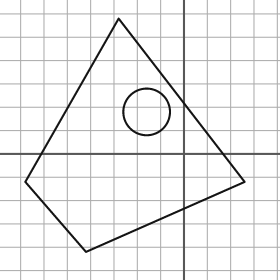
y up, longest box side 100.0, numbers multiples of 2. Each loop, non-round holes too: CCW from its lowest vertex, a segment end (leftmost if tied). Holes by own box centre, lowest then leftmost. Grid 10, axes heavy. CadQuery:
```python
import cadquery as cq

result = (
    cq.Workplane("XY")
    .moveTo(-42.0, -42.0)
    .lineTo(26.0, -12.0)
    .lineTo(-28.0, 58.0)
    .lineTo(-68.0, -12.0)
    .close()
    .moveTo(-16.0, 18.0)
    .circle(10.0)
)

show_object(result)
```